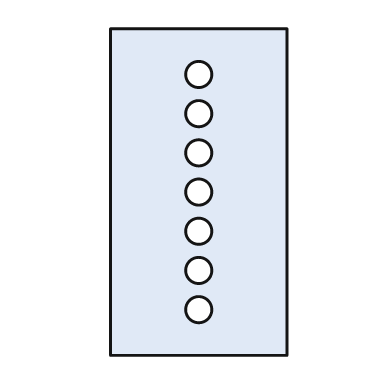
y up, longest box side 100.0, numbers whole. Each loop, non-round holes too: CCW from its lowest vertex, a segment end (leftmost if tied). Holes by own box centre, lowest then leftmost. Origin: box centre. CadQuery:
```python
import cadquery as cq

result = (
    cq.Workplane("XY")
    .moveTo(-27.0, -50.0)
    .lineTo(27.0, -50.0)
    .lineTo(27.0, 50.0)
    .lineTo(-27.0, 50.0)
    .close()
    .moveTo(0.0, -36.0)
    .circle(4.0)
    .moveTo(0.0, -24.0)
    .circle(4.0)
    .moveTo(0.0, -12.0)
    .circle(4.0)
    .moveTo(0.0, 0.0)
    .circle(4.0)
    .moveTo(0.0, 12.0)
    .circle(4.0)
    .moveTo(0.0, 24.0)
    .circle(4.0)
    .moveTo(0.0, 36.0)
    .circle(4.0)
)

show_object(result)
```